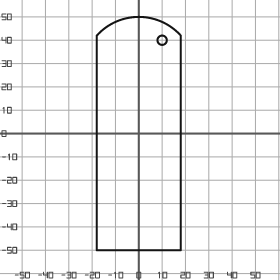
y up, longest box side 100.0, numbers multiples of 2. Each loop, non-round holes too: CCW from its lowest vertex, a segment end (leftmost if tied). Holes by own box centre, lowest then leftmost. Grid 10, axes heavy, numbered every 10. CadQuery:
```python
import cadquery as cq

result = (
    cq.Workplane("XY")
    .moveTo(-18.0, -50.0)
    .lineTo(18.0, -50.0)
    .lineTo(18.0, 42.0)
    .threePointArc((0.0, 50.0), (-18.0, 42.0))
    .close()
    .moveTo(10.0, 40.0)
    .circle(2.0)
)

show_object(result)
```